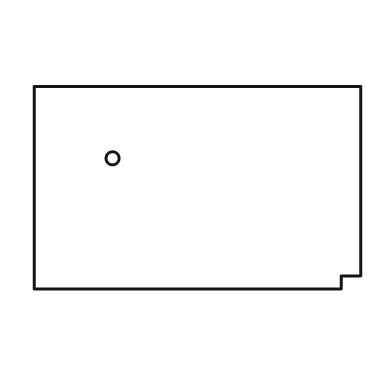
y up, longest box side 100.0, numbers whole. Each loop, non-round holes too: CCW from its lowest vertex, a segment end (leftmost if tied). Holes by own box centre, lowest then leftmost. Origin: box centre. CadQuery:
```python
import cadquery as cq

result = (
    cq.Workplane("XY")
    .moveTo(-50.0, -31.0)
    .lineTo(44.0, -31.0)
    .lineTo(44.0, -27.0)
    .lineTo(50.0, -27.0)
    .lineTo(50.0, 31.0)
    .lineTo(-50.0, 31.0)
    .close()
    .moveTo(-26.0, 9.0)
    .circle(2.0)
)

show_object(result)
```